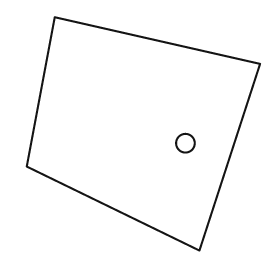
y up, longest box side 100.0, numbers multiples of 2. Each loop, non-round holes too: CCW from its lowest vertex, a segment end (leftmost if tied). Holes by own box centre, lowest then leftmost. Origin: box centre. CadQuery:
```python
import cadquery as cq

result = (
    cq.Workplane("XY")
    .moveTo(24.0, -50.0)
    .lineTo(50.0, 30.0)
    .lineTo(-38.0, 50.0)
    .lineTo(-50.0, -14.0)
    .close()
    .moveTo(18.0, -4.0)
    .circle(4.0)
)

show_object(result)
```